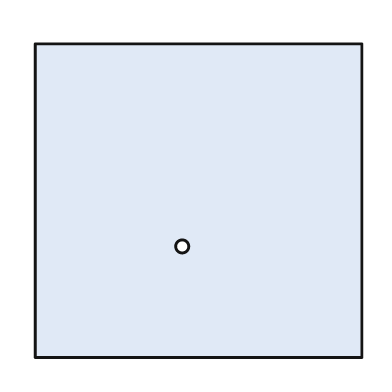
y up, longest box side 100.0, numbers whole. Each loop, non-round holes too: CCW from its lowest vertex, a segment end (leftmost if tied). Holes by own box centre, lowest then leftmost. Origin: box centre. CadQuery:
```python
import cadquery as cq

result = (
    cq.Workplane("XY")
    .moveTo(-50.0, -48.0)
    .lineTo(50.0, -48.0)
    .lineTo(50.0, 48.0)
    .lineTo(-50.0, 48.0)
    .close()
    .moveTo(-5.0, -14.0)
    .circle(2.0)
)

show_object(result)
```